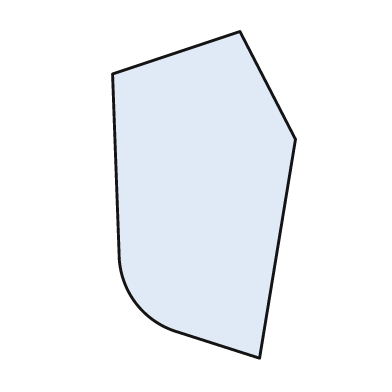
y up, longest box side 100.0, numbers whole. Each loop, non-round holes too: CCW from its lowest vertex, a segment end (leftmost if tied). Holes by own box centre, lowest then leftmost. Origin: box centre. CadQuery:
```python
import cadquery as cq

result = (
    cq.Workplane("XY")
    .moveTo(17.0, -50.0)
    .lineTo(28.0, 17.0)
    .lineTo(11.0, 50.0)
    .lineTo(-28.0, 37.0)
    .lineTo(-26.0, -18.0)
    .threePointArc((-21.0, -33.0), (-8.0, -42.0))
    .close()
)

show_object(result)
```